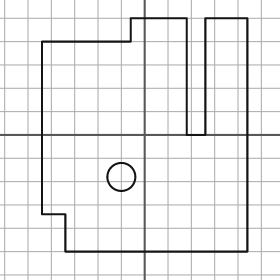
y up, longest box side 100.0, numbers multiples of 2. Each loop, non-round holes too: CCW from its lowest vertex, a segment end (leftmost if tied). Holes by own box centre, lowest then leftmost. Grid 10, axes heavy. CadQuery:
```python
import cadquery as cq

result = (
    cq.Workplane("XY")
    .moveTo(-34.0, -50.0)
    .lineTo(44.0, -50.0)
    .lineTo(44.0, 50.0)
    .lineTo(26.0, 50.0)
    .lineTo(26.0, 0.0)
    .lineTo(18.0, 0.0)
    .lineTo(18.0, 50.0)
    .lineTo(-6.0, 50.0)
    .lineTo(-6.0, 40.0)
    .lineTo(-44.0, 40.0)
    .lineTo(-44.0, -34.0)
    .lineTo(-34.0, -34.0)
    .close()
    .moveTo(-10.0, -18.0)
    .circle(6.0)
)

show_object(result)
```